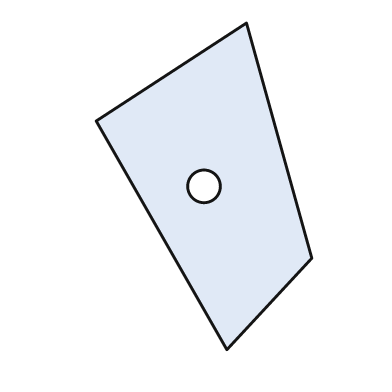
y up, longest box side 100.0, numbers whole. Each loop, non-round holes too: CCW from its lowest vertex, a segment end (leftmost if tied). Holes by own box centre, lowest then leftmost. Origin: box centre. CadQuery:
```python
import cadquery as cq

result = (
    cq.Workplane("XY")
    .moveTo(7.0, -50.0)
    .lineTo(33.0, -22.0)
    .lineTo(13.0, 50.0)
    .lineTo(-33.0, 20.0)
    .close()
    .moveTo(0.0, 0.0)
    .circle(5.0)
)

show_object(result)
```